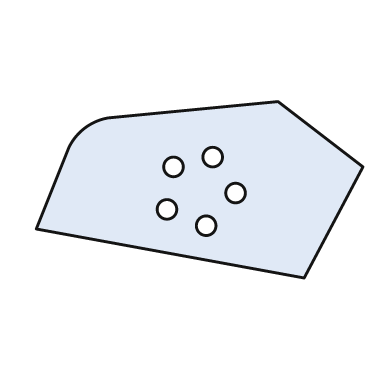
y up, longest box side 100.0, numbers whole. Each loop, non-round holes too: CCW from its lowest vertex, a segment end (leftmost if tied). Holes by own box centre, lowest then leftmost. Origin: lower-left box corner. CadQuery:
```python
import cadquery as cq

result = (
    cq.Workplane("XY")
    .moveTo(82.0, 0.0)
    .lineTo(100.0, 34.0)
    .lineTo(74.0, 54.0)
    .lineTo(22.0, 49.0)
    .threePointArc((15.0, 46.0), (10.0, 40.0))
    .lineTo(0.0, 15.0)
    .close()
    .moveTo(52.0, 16.0)
    .circle(3.0)
    .moveTo(40.0, 21.0)
    .circle(3.0)
    .moveTo(61.0, 26.0)
    .circle(3.0)
    .moveTo(42.0, 34.0)
    .circle(3.0)
    .moveTo(54.0, 37.0)
    .circle(3.0)
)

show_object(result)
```